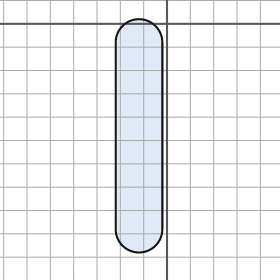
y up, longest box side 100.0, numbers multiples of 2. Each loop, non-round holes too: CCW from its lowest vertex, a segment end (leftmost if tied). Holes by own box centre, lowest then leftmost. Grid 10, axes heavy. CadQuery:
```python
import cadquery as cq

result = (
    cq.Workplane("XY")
    .moveTo(-22.0, -88.0)
    .threePointArc((-12.0, -98.0), (-2.0, -88.0))
    .lineTo(-2.0, -8.0)
    .threePointArc((-12.0, 2.0), (-22.0, -8.0))
    .close()
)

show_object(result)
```